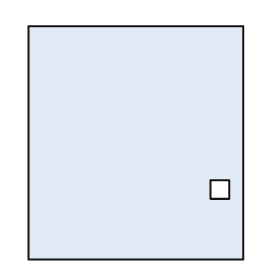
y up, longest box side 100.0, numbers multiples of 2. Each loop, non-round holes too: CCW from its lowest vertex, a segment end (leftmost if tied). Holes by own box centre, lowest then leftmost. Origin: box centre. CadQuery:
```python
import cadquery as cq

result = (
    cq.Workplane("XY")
    .moveTo(-46.0, -50.0)
    .lineTo(46.0, -50.0)
    .lineTo(46.0, 50.0)
    .lineTo(-46.0, 50.0)
    .close()
    .moveTo(32.0, -24.0)
    .lineTo(40.0, -24.0)
    .lineTo(40.0, -16.0)
    .lineTo(32.0, -16.0)
    .close()
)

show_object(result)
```